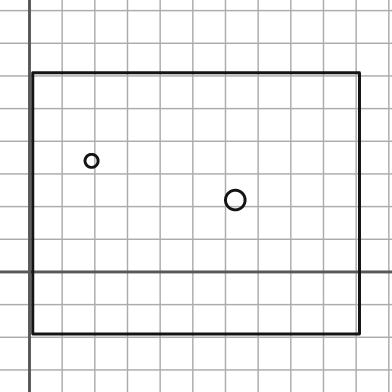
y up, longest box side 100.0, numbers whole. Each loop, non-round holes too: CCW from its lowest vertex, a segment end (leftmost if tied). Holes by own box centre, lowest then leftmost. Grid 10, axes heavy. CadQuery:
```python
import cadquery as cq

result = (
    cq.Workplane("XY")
    .moveTo(1.0, -19.0)
    .lineTo(101.0, -19.0)
    .lineTo(101.0, 61.0)
    .lineTo(1.0, 61.0)
    .close()
    .moveTo(63.0, 22.0)
    .circle(3.0)
    .moveTo(19.0, 34.0)
    .circle(2.0)
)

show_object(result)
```